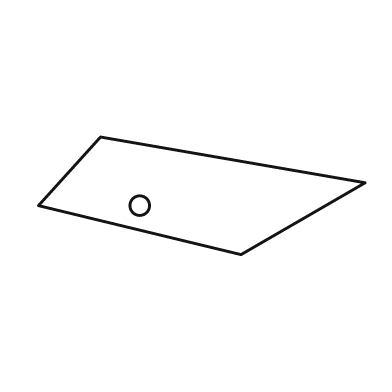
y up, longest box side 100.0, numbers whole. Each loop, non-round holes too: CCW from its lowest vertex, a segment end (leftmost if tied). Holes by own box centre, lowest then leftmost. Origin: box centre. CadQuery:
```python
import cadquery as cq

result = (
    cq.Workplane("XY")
    .moveTo(12.0, -18.0)
    .lineTo(50.0, 4.0)
    .lineTo(-31.0, 18.0)
    .lineTo(-50.0, -3.0)
    .close()
    .moveTo(-19.0, -3.0)
    .circle(3.0)
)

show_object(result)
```